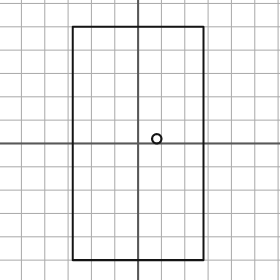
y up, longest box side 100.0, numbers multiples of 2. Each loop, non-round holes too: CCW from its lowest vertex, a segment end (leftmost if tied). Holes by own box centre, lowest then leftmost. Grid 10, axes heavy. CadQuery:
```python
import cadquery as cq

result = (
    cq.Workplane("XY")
    .moveTo(-28.0, -50.0)
    .lineTo(28.0, -50.0)
    .lineTo(28.0, 50.0)
    .lineTo(-28.0, 50.0)
    .close()
    .moveTo(8.0, 2.0)
    .circle(2.0)
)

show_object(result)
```